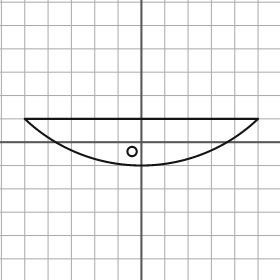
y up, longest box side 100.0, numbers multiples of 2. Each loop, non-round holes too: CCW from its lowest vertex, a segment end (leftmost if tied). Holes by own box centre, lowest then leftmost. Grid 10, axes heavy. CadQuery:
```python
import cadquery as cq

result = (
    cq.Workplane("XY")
    .moveTo(-50.0, 10.0)
    .threePointArc((0.0, -10.0), (50.0, 10.0))
    .close()
    .moveTo(-4.0, -4.0)
    .circle(2.0)
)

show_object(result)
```